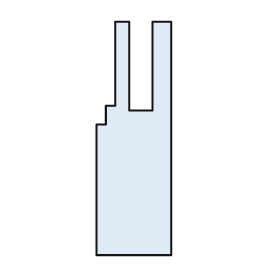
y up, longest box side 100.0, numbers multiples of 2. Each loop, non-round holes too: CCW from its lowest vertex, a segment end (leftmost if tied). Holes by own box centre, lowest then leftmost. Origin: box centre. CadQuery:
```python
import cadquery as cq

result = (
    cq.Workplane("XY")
    .moveTo(-16.0, -50.0)
    .lineTo(16.0, -50.0)
    .lineTo(16.0, 50.0)
    .lineTo(8.0, 50.0)
    .lineTo(8.0, 12.0)
    .lineTo(-2.0, 12.0)
    .lineTo(-2.0, 50.0)
    .lineTo(-8.0, 50.0)
    .lineTo(-8.0, 14.0)
    .lineTo(-12.0, 14.0)
    .lineTo(-12.0, 6.0)
    .lineTo(-16.0, 6.0)
    .close()
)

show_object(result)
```